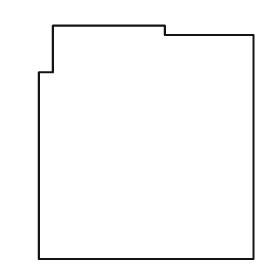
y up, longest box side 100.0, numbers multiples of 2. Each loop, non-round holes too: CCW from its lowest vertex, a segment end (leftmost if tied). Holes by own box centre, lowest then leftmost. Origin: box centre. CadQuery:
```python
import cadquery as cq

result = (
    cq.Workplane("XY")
    .moveTo(-46.0, -50.0)
    .lineTo(46.0, -50.0)
    .lineTo(46.0, 46.0)
    .lineTo(8.0, 46.0)
    .lineTo(8.0, 50.0)
    .lineTo(-40.0, 50.0)
    .lineTo(-40.0, 30.0)
    .lineTo(-46.0, 30.0)
    .close()
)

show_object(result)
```